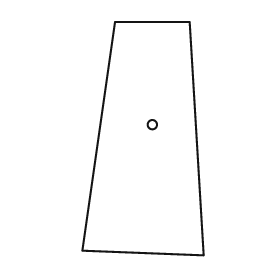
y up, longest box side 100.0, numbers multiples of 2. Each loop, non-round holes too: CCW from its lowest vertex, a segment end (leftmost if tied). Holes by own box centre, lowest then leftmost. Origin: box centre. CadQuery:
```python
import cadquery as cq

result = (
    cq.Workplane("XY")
    .moveTo(26.0, -50.0)
    .lineTo(20.0, 50.0)
    .lineTo(-12.0, 50.0)
    .lineTo(-26.0, -48.0)
    .close()
    .moveTo(4.0, 6.0)
    .circle(2.0)
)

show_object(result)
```